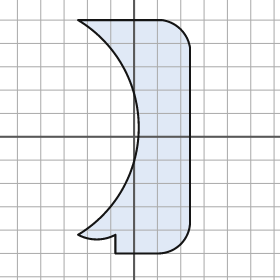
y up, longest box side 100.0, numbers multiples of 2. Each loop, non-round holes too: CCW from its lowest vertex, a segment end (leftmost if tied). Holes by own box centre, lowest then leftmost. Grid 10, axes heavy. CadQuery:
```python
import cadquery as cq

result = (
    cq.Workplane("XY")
    .moveTo(-8.0, -50.0)
    .lineTo(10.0, -50.0)
    .threePointArc((20.0, -46.0), (24.0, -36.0))
    .lineTo(24.0, 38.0)
    .threePointArc((20.0, 46.0), (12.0, 50.0))
    .lineTo(-24.0, 50.0)
    .threePointArc((2.0, 4.0), (-24.0, -42.0))
    .threePointArc((-16.0, -44.0), (-8.0, -42.0))
    .close()
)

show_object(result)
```